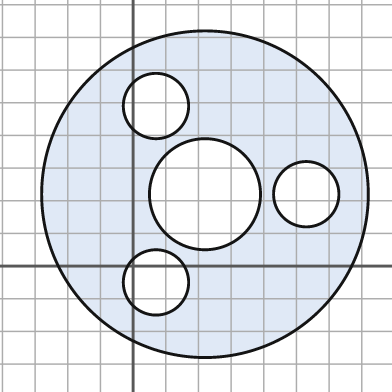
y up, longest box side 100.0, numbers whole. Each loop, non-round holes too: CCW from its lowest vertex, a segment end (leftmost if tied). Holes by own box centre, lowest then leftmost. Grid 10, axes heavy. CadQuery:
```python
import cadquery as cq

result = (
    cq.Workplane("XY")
    .moveTo(22.0, 22.0)
    .circle(50.0)
    .moveTo(7.0, -5.0)
    .circle(10.0)
    .moveTo(22.0, 22.0)
    .circle(17.0)
    .moveTo(53.0, 22.0)
    .circle(10.0)
    .moveTo(7.0, 49.0)
    .circle(10.0)
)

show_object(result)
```